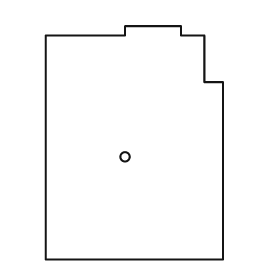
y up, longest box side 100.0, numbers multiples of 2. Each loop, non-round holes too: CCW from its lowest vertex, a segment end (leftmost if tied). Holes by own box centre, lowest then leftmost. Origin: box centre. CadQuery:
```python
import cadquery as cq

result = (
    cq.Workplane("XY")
    .moveTo(-38.0, -50.0)
    .lineTo(38.0, -50.0)
    .lineTo(38.0, 26.0)
    .lineTo(30.0, 26.0)
    .lineTo(30.0, 46.0)
    .lineTo(20.0, 46.0)
    .lineTo(20.0, 50.0)
    .lineTo(-4.0, 50.0)
    .lineTo(-4.0, 46.0)
    .lineTo(-38.0, 46.0)
    .close()
    .moveTo(-4.0, -6.0)
    .circle(2.0)
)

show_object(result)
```